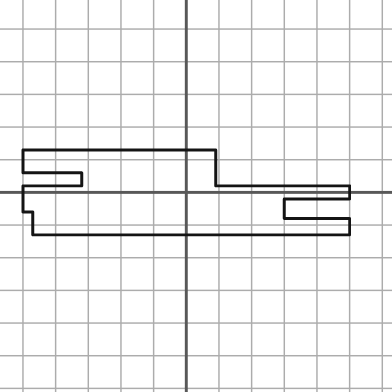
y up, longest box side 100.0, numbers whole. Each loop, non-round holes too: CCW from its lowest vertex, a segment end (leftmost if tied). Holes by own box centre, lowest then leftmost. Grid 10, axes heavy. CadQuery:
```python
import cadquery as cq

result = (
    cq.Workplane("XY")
    .moveTo(-47.0, -13.0)
    .lineTo(50.0, -13.0)
    .lineTo(50.0, -8.0)
    .lineTo(30.0, -8.0)
    .lineTo(30.0, -2.0)
    .lineTo(50.0, -2.0)
    .lineTo(50.0, 2.0)
    .lineTo(9.0, 2.0)
    .lineTo(9.0, 13.0)
    .lineTo(-50.0, 13.0)
    .lineTo(-50.0, 6.0)
    .lineTo(-32.0, 6.0)
    .lineTo(-32.0, 2.0)
    .lineTo(-50.0, 2.0)
    .lineTo(-50.0, -6.0)
    .lineTo(-47.0, -6.0)
    .close()
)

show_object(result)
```